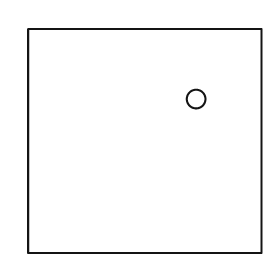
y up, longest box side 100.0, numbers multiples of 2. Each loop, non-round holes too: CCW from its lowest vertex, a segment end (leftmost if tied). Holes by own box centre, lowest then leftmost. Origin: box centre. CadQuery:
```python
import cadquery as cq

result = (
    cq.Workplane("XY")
    .moveTo(-50.0, -48.0)
    .lineTo(50.0, -48.0)
    .lineTo(50.0, 48.0)
    .lineTo(-50.0, 48.0)
    .close()
    .moveTo(22.0, 18.0)
    .circle(4.0)
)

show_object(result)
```